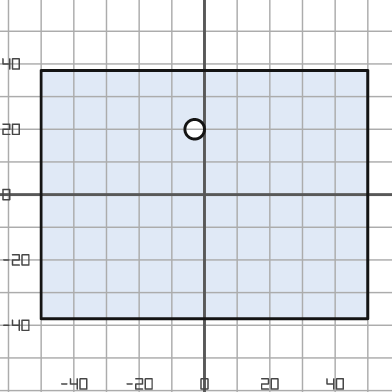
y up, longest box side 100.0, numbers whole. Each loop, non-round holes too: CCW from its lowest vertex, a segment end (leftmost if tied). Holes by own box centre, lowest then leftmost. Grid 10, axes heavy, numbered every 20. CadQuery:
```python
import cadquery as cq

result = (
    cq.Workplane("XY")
    .moveTo(-50.0, -38.0)
    .lineTo(50.0, -38.0)
    .lineTo(50.0, 38.0)
    .lineTo(-50.0, 38.0)
    .close()
    .moveTo(-3.0, 20.0)
    .circle(3.0)
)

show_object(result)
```